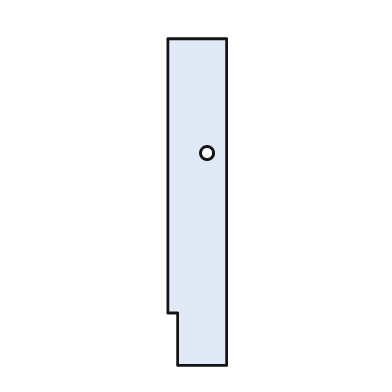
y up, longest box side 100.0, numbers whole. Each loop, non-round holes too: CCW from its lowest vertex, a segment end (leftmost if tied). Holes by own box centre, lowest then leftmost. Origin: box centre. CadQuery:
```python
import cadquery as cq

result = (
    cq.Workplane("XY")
    .moveTo(-6.0, -50.0)
    .lineTo(9.0, -50.0)
    .lineTo(9.0, 50.0)
    .lineTo(-9.0, 50.0)
    .lineTo(-9.0, -34.0)
    .lineTo(-6.0, -34.0)
    .close()
    .moveTo(3.0, 15.0)
    .circle(2.0)
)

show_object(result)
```